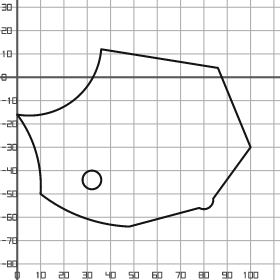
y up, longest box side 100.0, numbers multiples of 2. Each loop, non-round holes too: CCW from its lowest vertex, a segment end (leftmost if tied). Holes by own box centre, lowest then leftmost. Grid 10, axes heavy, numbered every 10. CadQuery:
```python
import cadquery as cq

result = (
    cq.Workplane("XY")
    .moveTo(48.0, -64.0)
    .lineTo(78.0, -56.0)
    .threePointArc((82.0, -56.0), (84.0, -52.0))
    .lineTo(100.0, -30.0)
    .lineTo(86.0, 4.0)
    .lineTo(36.0, 12.0)
    .threePointArc((24.0, -10.0), (0.0, -16.0))
    .threePointArc((8.0, -32.0), (10.0, -50.0))
    .threePointArc((28.0, -60.0), (48.0, -64.0))
    .close()
    .moveTo(32.0, -44.0)
    .circle(4.0)
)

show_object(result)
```